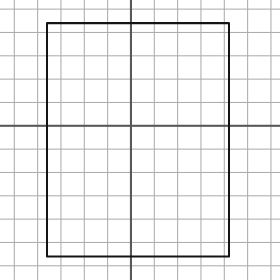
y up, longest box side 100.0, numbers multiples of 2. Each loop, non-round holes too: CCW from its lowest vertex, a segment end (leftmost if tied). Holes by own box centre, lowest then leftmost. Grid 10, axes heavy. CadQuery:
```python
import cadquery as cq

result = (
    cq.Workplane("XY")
    .moveTo(-36.0, -56.0)
    .lineTo(42.0, -56.0)
    .lineTo(42.0, 44.0)
    .lineTo(-36.0, 44.0)
    .close()
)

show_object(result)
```